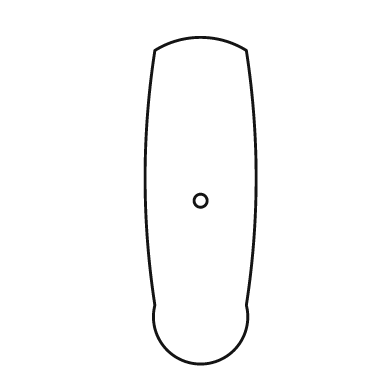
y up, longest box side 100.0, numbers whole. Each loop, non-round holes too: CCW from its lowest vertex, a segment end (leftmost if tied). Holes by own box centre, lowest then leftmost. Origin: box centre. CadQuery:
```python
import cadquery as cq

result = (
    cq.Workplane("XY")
    .moveTo(-14.0, -32.0)
    .threePointArc((0.0, -50.0), (14.0, -32.0))
    .threePointArc((17.0, 7.0), (14.0, 46.0))
    .threePointArc((0.0, 50.0), (-14.0, 46.0))
    .threePointArc((-17.0, 7.0), (-14.0, -32.0))
    .close()
    .moveTo(0.0, 0.0)
    .circle(2.0)
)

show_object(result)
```